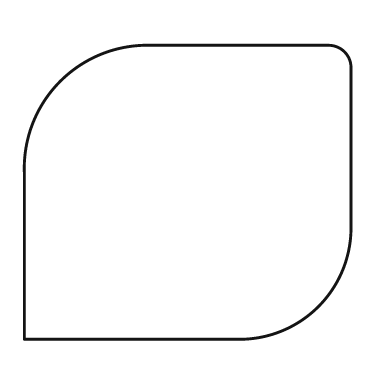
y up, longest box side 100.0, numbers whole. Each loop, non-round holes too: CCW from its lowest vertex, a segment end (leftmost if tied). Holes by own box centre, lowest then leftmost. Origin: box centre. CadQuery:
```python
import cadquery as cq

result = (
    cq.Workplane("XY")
    .moveTo(-50.0, -45.0)
    .lineTo(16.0, -45.0)
    .threePointArc((40.0, -35.0), (50.0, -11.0))
    .lineTo(50.0, 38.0)
    .threePointArc((48.0, 43.0), (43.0, 45.0))
    .lineTo(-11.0, 45.0)
    .threePointArc((-39.0, 34.0), (-50.0, 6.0))
    .close()
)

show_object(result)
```